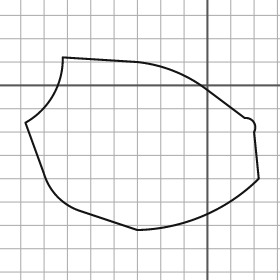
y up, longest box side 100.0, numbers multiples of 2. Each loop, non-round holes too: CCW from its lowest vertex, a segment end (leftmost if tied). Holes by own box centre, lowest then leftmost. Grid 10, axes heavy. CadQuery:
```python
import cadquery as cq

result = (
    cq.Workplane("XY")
    .moveTo(-30.0, -62.0)
    .threePointArc((-2.0, -56.0), (22.0, -40.0))
    .lineTo(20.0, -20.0)
    .threePointArc((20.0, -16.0), (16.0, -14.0))
    .lineTo(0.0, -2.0)
    .threePointArc((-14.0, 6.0), (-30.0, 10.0))
    .lineTo(-62.0, 12.0)
    .threePointArc((-66.0, -4.0), (-78.0, -16.0))
    .lineTo(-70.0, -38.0)
    .threePointArc((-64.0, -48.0), (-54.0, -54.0))
    .close()
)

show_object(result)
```